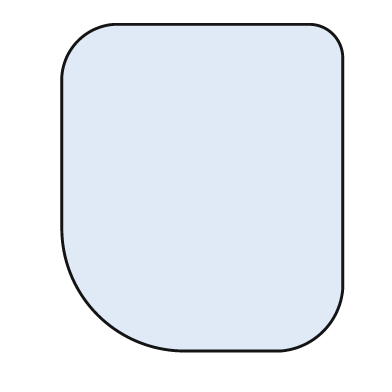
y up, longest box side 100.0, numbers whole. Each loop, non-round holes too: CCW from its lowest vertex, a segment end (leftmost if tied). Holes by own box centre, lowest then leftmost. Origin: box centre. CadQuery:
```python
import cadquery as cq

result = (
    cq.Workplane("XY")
    .moveTo(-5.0, -50.0)
    .lineTo(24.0, -50.0)
    .threePointArc((37.0, -44.0), (43.0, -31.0))
    .lineTo(43.0, 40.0)
    .threePointArc((40.0, 47.0), (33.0, 50.0))
    .lineTo(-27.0, 50.0)
    .threePointArc((-38.0, 45.0), (-43.0, 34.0))
    .lineTo(-43.0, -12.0)
    .threePointArc((-32.0, -39.0), (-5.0, -50.0))
    .close()
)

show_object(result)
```